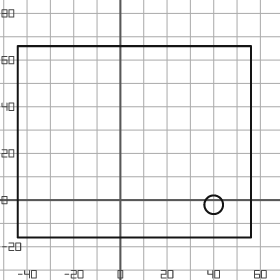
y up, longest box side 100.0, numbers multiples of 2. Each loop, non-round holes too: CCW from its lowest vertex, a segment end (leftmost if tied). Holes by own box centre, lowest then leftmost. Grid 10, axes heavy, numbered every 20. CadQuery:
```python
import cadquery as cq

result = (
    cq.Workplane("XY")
    .moveTo(-44.0, -16.0)
    .lineTo(56.0, -16.0)
    .lineTo(56.0, 66.0)
    .lineTo(-44.0, 66.0)
    .close()
    .moveTo(40.0, -2.0)
    .circle(4.0)
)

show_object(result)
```